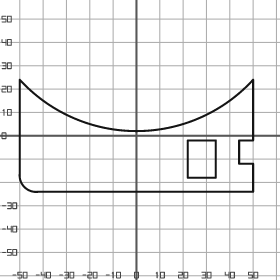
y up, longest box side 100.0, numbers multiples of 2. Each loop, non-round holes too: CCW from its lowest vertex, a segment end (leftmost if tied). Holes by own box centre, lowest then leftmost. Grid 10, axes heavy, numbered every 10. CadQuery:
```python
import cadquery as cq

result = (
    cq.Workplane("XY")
    .moveTo(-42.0, -24.0)
    .lineTo(50.0, -24.0)
    .lineTo(50.0, -12.0)
    .lineTo(44.0, -12.0)
    .lineTo(44.0, -2.0)
    .lineTo(50.0, -2.0)
    .lineTo(50.0, 24.0)
    .threePointArc((0.0, 2.0), (-50.0, 24.0))
    .lineTo(-50.0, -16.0)
    .threePointArc((-48.0, -22.0), (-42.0, -24.0))
    .close()
    .moveTo(22.0, -18.0)
    .lineTo(34.0, -18.0)
    .lineTo(34.0, -2.0)
    .lineTo(22.0, -2.0)
    .close()
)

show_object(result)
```